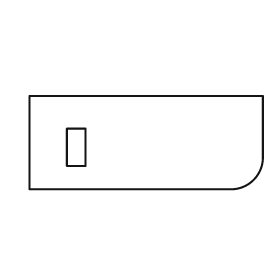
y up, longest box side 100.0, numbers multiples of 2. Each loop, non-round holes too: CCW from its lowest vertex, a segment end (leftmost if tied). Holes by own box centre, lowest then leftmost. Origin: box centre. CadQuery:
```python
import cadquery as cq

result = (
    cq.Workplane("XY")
    .moveTo(-50.0, -20.0)
    .lineTo(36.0, -20.0)
    .threePointArc((46.0, -16.0), (50.0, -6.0))
    .lineTo(50.0, 20.0)
    .lineTo(-50.0, 20.0)
    .close()
    .moveTo(-34.0, -10.0)
    .lineTo(-26.0, -10.0)
    .lineTo(-26.0, 6.0)
    .lineTo(-34.0, 6.0)
    .close()
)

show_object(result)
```